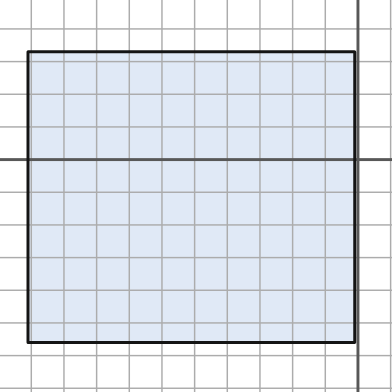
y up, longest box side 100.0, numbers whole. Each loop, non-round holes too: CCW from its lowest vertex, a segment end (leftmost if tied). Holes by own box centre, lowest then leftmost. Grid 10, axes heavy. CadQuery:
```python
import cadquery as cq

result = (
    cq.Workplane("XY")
    .moveTo(-101.0, -56.0)
    .lineTo(-1.0, -56.0)
    .lineTo(-1.0, 33.0)
    .lineTo(-101.0, 33.0)
    .close()
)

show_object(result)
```